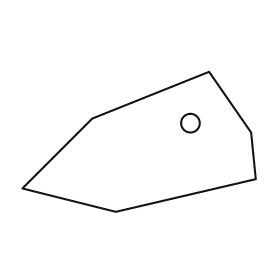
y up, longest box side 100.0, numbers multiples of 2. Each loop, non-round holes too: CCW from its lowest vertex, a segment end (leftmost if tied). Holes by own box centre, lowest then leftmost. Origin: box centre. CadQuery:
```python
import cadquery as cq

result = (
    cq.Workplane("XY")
    .moveTo(-10.0, -30.0)
    .lineTo(50.0, -16.0)
    .lineTo(48.0, 4.0)
    .lineTo(30.0, 30.0)
    .lineTo(-20.0, 10.0)
    .lineTo(-50.0, -20.0)
    .close()
    .moveTo(22.0, 8.0)
    .circle(4.0)
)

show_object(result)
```